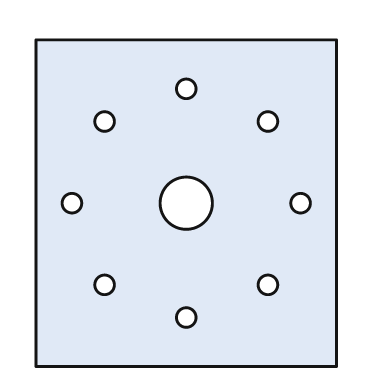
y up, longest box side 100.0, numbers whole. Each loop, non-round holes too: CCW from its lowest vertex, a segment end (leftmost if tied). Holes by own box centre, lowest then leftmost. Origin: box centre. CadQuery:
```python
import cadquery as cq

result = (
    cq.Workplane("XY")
    .moveTo(-46.0, -50.0)
    .lineTo(46.0, -50.0)
    .lineTo(46.0, 50.0)
    .lineTo(-46.0, 50.0)
    .close()
    .moveTo(0.0, -35.0)
    .circle(3.0)
    .moveTo(-25.0, -25.0)
    .circle(3.0)
    .moveTo(25.0, -25.0)
    .circle(3.0)
    .moveTo(-35.0, 0.0)
    .circle(3.0)
    .moveTo(0.0, 0.0)
    .circle(8.0)
    .moveTo(35.0, 0.0)
    .circle(3.0)
    .moveTo(-25.0, 25.0)
    .circle(3.0)
    .moveTo(25.0, 25.0)
    .circle(3.0)
    .moveTo(0.0, 35.0)
    .circle(3.0)
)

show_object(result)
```